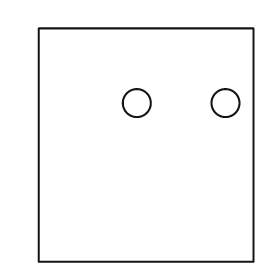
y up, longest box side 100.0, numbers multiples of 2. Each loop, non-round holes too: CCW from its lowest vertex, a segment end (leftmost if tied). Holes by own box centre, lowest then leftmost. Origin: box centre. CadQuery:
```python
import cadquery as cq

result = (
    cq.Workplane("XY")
    .moveTo(-46.0, -50.0)
    .lineTo(46.0, -50.0)
    .lineTo(46.0, 50.0)
    .lineTo(-46.0, 50.0)
    .close()
    .moveTo(-4.0, 18.0)
    .circle(6.0)
    .moveTo(34.0, 18.0)
    .circle(6.0)
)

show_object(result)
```